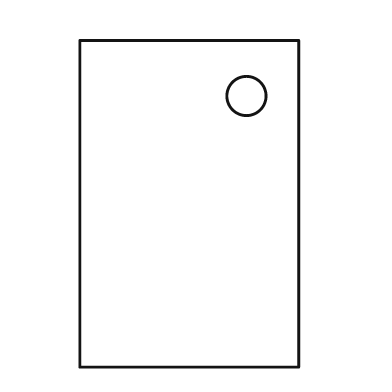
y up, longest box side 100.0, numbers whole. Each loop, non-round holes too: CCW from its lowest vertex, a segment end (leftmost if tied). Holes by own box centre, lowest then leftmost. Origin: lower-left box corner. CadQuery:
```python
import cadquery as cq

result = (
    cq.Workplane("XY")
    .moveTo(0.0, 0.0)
    .lineTo(67.0, 0.0)
    .lineTo(67.0, 100.0)
    .lineTo(0.0, 100.0)
    .close()
    .moveTo(51.0, 83.0)
    .circle(6.0)
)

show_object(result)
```